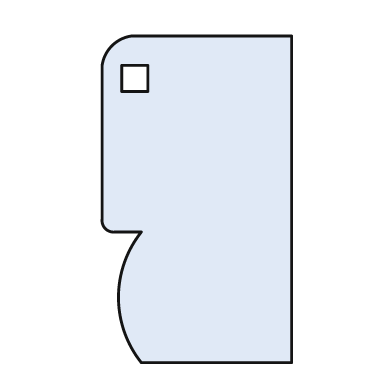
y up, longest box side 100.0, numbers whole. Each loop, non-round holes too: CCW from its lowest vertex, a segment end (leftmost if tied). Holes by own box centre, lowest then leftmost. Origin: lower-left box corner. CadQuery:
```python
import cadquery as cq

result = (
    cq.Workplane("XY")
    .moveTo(12.0, 0.0)
    .lineTo(58.0, 0.0)
    .lineTo(58.0, 100.0)
    .lineTo(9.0, 100.0)
    .threePointArc((3.0, 97.0), (0.0, 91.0))
    .lineTo(0.0, 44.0)
    .threePointArc((1.0, 41.0), (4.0, 40.0))
    .lineTo(12.0, 40.0)
    .threePointArc((5.0, 20.0), (12.0, 0.0))
    .close()
    .moveTo(6.0, 83.0)
    .lineTo(14.0, 83.0)
    .lineTo(14.0, 91.0)
    .lineTo(6.0, 91.0)
    .close()
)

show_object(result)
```